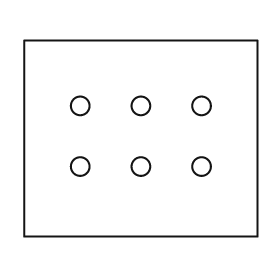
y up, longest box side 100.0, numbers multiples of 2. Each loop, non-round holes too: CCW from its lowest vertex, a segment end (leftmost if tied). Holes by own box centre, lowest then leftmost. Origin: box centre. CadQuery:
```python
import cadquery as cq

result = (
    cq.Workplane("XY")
    .moveTo(-50.0, -42.0)
    .lineTo(50.0, -42.0)
    .lineTo(50.0, 42.0)
    .lineTo(-50.0, 42.0)
    .close()
    .moveTo(-26.0, -12.0)
    .circle(4.0)
    .moveTo(0.0, -12.0)
    .circle(4.0)
    .moveTo(26.0, -12.0)
    .circle(4.0)
    .moveTo(-26.0, 14.0)
    .circle(4.0)
    .moveTo(0.0, 14.0)
    .circle(4.0)
    .moveTo(26.0, 14.0)
    .circle(4.0)
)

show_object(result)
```